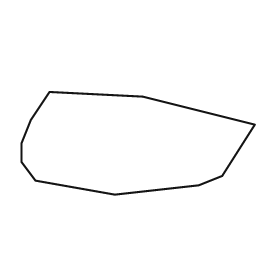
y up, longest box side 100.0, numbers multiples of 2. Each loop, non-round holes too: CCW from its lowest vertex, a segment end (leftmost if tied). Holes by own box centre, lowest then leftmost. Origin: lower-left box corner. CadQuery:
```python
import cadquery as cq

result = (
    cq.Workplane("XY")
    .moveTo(40.0, 0.0)
    .lineTo(76.0, 4.0)
    .lineTo(86.0, 8.0)
    .lineTo(100.0, 30.0)
    .lineTo(52.0, 42.0)
    .lineTo(12.0, 44.0)
    .lineTo(4.0, 32.0)
    .lineTo(0.0, 22.0)
    .lineTo(0.0, 14.0)
    .lineTo(6.0, 6.0)
    .close()
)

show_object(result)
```